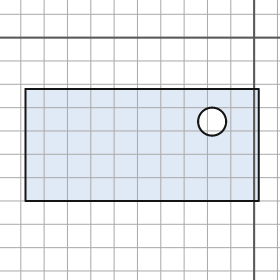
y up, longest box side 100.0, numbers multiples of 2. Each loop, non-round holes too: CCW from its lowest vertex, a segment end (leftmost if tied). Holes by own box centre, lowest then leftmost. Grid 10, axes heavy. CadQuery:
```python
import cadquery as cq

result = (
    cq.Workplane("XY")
    .moveTo(-98.0, -70.0)
    .lineTo(2.0, -70.0)
    .lineTo(2.0, -22.0)
    .lineTo(-98.0, -22.0)
    .close()
    .moveTo(-18.0, -36.0)
    .circle(6.0)
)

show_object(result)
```